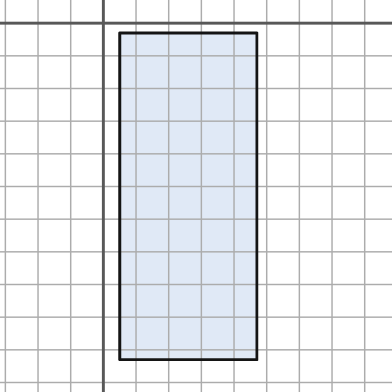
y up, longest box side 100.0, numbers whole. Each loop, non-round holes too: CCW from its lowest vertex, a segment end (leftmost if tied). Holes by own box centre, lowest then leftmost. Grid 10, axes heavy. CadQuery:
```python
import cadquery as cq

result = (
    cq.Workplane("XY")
    .moveTo(5.0, -103.0)
    .lineTo(47.0, -103.0)
    .lineTo(47.0, -3.0)
    .lineTo(5.0, -3.0)
    .close()
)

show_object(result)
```